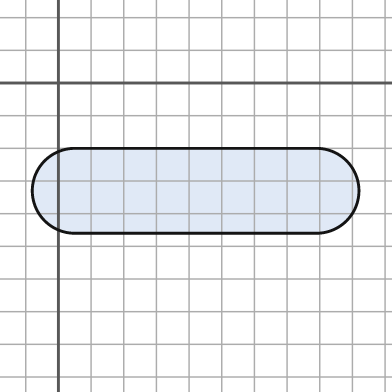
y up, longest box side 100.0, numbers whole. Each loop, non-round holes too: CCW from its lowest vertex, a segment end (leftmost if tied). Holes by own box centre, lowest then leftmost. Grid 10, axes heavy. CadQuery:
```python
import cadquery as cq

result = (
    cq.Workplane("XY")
    .moveTo(5.0, -46.0)
    .lineTo(79.0, -46.0)
    .threePointArc((92.0, -33.0), (79.0, -20.0))
    .lineTo(5.0, -20.0)
    .threePointArc((-8.0, -33.0), (5.0, -46.0))
    .close()
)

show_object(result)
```